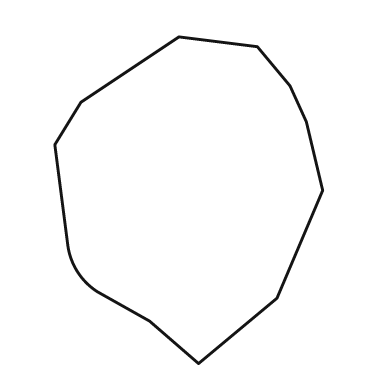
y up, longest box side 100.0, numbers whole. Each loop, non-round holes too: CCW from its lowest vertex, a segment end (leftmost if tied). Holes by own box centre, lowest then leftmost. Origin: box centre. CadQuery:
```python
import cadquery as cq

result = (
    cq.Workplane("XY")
    .moveTo(3.0, -50.0)
    .lineTo(27.0, -30.0)
    .lineTo(41.0, 3.0)
    .lineTo(36.0, 24.0)
    .lineTo(31.0, 35.0)
    .lineTo(21.0, 47.0)
    .lineTo(-3.0, 50.0)
    .lineTo(-33.0, 30.0)
    .lineTo(-41.0, 17.0)
    .lineTo(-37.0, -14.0)
    .threePointArc((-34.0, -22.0), (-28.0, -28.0))
    .lineTo(-12.0, -37.0)
    .close()
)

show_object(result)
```